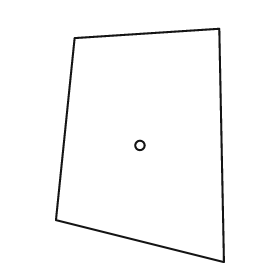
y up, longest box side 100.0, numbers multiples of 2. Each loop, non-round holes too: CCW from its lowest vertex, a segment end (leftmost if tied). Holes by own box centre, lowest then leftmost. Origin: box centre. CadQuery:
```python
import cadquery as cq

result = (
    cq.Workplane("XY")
    .moveTo(36.0, -50.0)
    .lineTo(34.0, 50.0)
    .lineTo(-28.0, 46.0)
    .lineTo(-36.0, -32.0)
    .close()
    .moveTo(0.0, 0.0)
    .circle(2.0)
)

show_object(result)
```